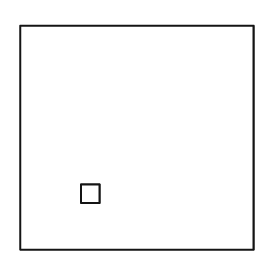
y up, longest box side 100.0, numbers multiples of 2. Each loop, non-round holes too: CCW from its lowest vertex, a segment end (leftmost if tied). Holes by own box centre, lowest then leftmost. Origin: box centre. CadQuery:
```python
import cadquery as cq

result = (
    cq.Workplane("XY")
    .moveTo(-50.0, -48.0)
    .lineTo(50.0, -48.0)
    .lineTo(50.0, 48.0)
    .lineTo(-50.0, 48.0)
    .close()
    .moveTo(-24.0, -28.0)
    .lineTo(-16.0, -28.0)
    .lineTo(-16.0, -20.0)
    .lineTo(-24.0, -20.0)
    .close()
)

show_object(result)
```